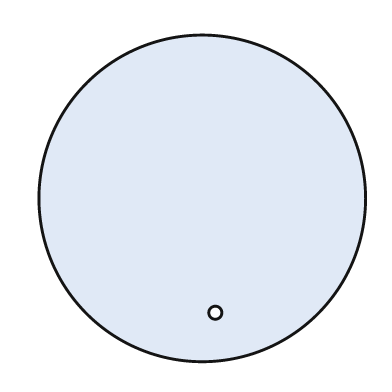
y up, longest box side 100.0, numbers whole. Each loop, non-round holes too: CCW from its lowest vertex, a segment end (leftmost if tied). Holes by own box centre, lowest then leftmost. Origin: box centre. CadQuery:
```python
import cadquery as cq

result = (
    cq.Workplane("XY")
    .moveTo(0.0, 0.0)
    .circle(50.0)
    .moveTo(4.0, -35.0)
    .circle(2.0)
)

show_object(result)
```